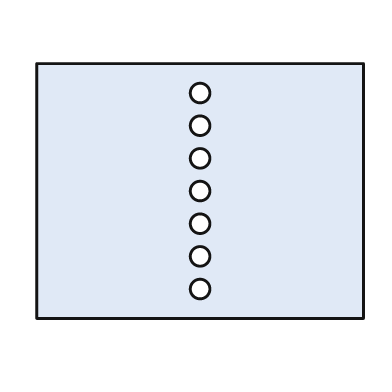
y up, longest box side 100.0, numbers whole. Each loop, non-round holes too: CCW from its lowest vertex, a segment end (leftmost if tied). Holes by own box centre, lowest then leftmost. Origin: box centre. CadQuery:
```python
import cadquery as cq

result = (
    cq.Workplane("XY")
    .moveTo(-50.0, -39.0)
    .lineTo(50.0, -39.0)
    .lineTo(50.0, 39.0)
    .lineTo(-50.0, 39.0)
    .close()
    .moveTo(0.0, -30.0)
    .circle(3.0)
    .moveTo(0.0, -20.0)
    .circle(3.0)
    .moveTo(0.0, -10.0)
    .circle(3.0)
    .moveTo(0.0, 0.0)
    .circle(3.0)
    .moveTo(0.0, 10.0)
    .circle(3.0)
    .moveTo(0.0, 20.0)
    .circle(3.0)
    .moveTo(0.0, 30.0)
    .circle(3.0)
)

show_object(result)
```